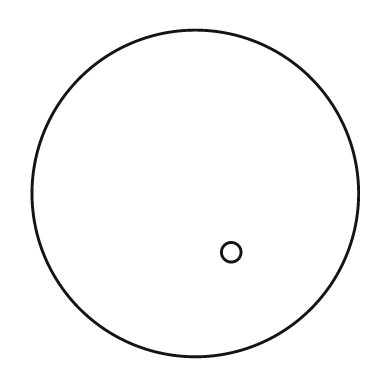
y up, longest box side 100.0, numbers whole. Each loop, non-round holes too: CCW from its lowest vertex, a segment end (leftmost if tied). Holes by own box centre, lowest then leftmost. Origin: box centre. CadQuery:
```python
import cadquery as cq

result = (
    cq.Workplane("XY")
    .moveTo(0.0, 0.0)
    .circle(50.0)
    .moveTo(11.0, -18.0)
    .circle(3.0)
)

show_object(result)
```